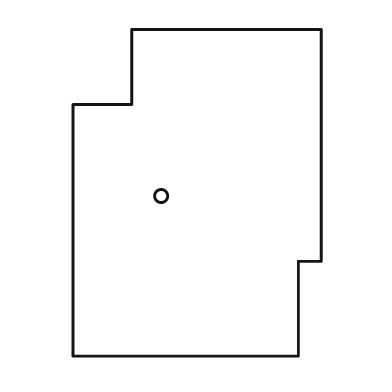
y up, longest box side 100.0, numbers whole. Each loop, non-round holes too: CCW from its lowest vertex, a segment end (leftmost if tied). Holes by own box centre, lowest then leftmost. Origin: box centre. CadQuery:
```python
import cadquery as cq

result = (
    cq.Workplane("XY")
    .moveTo(-38.0, -50.0)
    .lineTo(31.0, -50.0)
    .lineTo(31.0, -21.0)
    .lineTo(38.0, -21.0)
    .lineTo(38.0, 50.0)
    .lineTo(-20.0, 50.0)
    .lineTo(-20.0, 27.0)
    .lineTo(-38.0, 27.0)
    .close()
    .moveTo(-11.0, -1.0)
    .circle(2.0)
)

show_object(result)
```